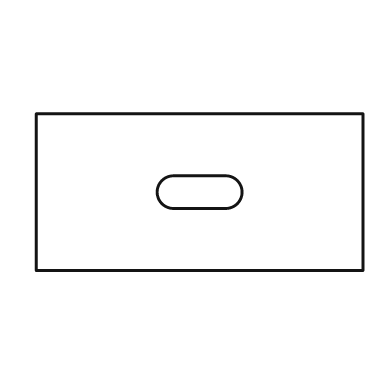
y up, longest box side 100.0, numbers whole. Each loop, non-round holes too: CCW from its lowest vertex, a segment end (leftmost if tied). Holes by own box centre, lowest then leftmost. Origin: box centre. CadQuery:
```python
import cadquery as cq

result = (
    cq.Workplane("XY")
    .moveTo(-50.0, -24.0)
    .lineTo(50.0, -24.0)
    .lineTo(50.0, 24.0)
    .lineTo(-50.0, 24.0)
    .close()
    .moveTo(-8.0, -5.0)
    .lineTo(8.0, -5.0)
    .threePointArc((13.0, 0.0), (8.0, 5.0))
    .lineTo(-8.0, 5.0)
    .threePointArc((-13.0, 0.0), (-8.0, -5.0))
    .close()
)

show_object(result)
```